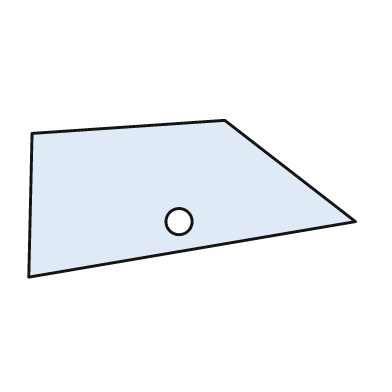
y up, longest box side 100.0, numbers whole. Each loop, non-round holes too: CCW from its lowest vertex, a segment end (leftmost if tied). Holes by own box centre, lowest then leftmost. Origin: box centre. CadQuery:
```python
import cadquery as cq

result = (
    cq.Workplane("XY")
    .moveTo(-50.0, -24.0)
    .lineTo(50.0, -7.0)
    .lineTo(10.0, 24.0)
    .lineTo(-49.0, 20.0)
    .close()
    .moveTo(-4.0, -7.0)
    .circle(4.0)
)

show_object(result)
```